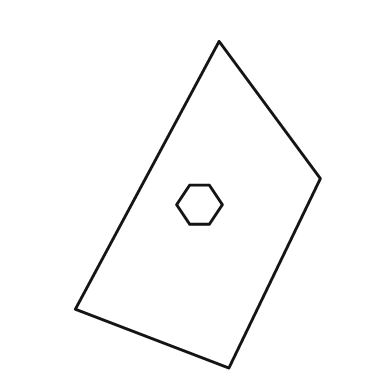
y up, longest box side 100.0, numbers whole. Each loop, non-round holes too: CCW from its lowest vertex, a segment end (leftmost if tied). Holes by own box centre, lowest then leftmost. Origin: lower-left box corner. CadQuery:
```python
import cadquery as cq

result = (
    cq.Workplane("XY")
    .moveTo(47.0, 0.0)
    .lineTo(75.0, 58.0)
    .lineTo(44.0, 100.0)
    .lineTo(0.0, 18.0)
    .close()
    .moveTo(35.0, 44.0)
    .lineTo(41.0, 44.0)
    .lineTo(45.0, 50.0)
    .lineTo(41.0, 56.0)
    .lineTo(35.0, 56.0)
    .lineTo(31.0, 50.0)
    .close()
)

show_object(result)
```